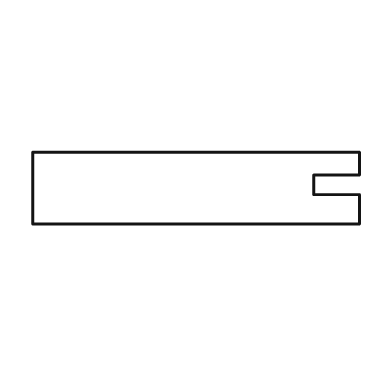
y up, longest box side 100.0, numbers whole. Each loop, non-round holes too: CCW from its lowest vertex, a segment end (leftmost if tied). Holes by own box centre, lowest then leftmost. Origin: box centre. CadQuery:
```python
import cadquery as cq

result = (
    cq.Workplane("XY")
    .moveTo(-50.0, -11.0)
    .lineTo(50.0, -11.0)
    .lineTo(50.0, -2.0)
    .lineTo(36.0, -2.0)
    .lineTo(36.0, 4.0)
    .lineTo(50.0, 4.0)
    .lineTo(50.0, 11.0)
    .lineTo(-50.0, 11.0)
    .close()
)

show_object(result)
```